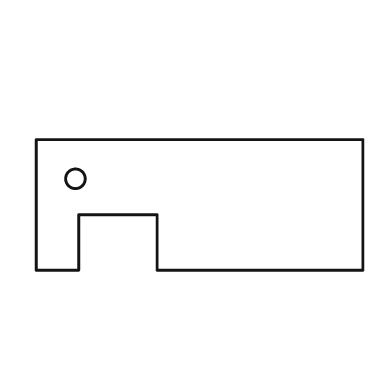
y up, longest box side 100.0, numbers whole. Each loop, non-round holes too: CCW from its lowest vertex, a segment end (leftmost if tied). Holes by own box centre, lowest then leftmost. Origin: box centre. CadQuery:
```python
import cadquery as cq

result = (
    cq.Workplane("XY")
    .moveTo(-50.0, -20.0)
    .lineTo(-37.0, -20.0)
    .lineTo(-37.0, -3.0)
    .lineTo(-13.0, -3.0)
    .lineTo(-13.0, -20.0)
    .lineTo(50.0, -20.0)
    .lineTo(50.0, 20.0)
    .lineTo(-50.0, 20.0)
    .close()
    .moveTo(-38.0, 8.0)
    .circle(3.0)
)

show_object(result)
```